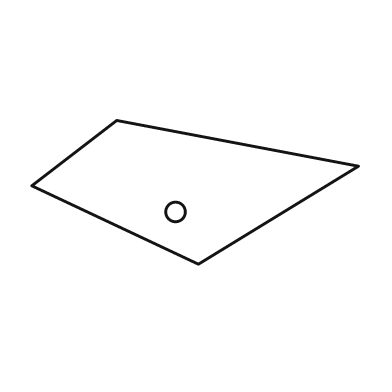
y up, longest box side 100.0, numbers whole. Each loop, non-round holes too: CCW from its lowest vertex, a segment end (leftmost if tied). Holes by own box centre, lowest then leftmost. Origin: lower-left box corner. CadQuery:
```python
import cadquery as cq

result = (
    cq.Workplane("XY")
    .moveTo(51.0, 0.0)
    .lineTo(100.0, 30.0)
    .lineTo(26.0, 44.0)
    .lineTo(0.0, 24.0)
    .close()
    .moveTo(44.0, 16.0)
    .circle(3.0)
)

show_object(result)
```